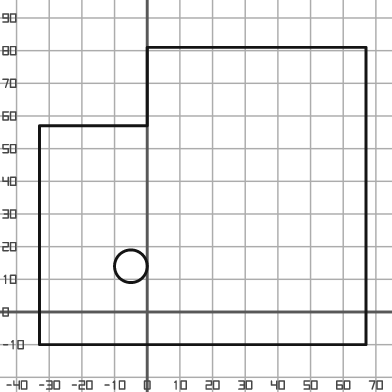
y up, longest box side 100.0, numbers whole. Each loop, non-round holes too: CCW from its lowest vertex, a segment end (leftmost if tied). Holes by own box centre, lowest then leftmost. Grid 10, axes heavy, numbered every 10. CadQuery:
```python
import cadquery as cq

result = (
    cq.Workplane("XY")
    .moveTo(-33.0, -10.0)
    .lineTo(67.0, -10.0)
    .lineTo(67.0, 81.0)
    .lineTo(0.0, 81.0)
    .lineTo(0.0, 57.0)
    .lineTo(-33.0, 57.0)
    .close()
    .moveTo(-5.0, 14.0)
    .circle(5.0)
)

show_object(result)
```